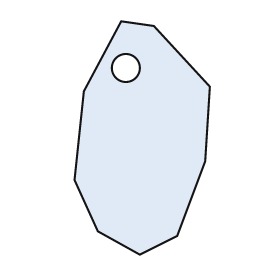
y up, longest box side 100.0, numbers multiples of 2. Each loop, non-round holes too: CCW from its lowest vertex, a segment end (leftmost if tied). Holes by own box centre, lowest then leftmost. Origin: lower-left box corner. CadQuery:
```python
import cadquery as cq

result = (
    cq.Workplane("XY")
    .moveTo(28.0, 0.0)
    .lineTo(44.0, 8.0)
    .lineTo(56.0, 40.0)
    .lineTo(58.0, 72.0)
    .lineTo(34.0, 98.0)
    .lineTo(20.0, 100.0)
    .lineTo(4.0, 70.0)
    .lineTo(0.0, 32.0)
    .lineTo(10.0, 10.0)
    .close()
    .moveTo(22.0, 80.0)
    .circle(6.0)
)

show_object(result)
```